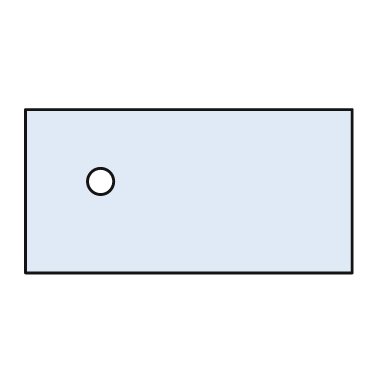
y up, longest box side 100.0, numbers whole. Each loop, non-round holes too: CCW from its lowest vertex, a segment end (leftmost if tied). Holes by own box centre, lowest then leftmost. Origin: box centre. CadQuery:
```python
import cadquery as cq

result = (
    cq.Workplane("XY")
    .moveTo(-50.0, -25.0)
    .lineTo(50.0, -25.0)
    .lineTo(50.0, 25.0)
    .lineTo(-50.0, 25.0)
    .close()
    .moveTo(-27.0, 3.0)
    .circle(4.0)
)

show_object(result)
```